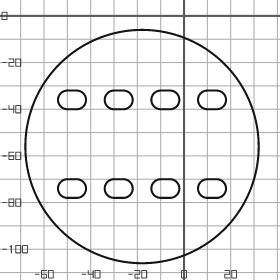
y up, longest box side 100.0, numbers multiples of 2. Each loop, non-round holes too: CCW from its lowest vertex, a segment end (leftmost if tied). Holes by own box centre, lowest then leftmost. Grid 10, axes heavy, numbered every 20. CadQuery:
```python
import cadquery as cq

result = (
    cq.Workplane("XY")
    .moveTo(-18.0, -56.0)
    .circle(50.0)
    .moveTo(-50.0, -78.0)
    .lineTo(-46.0, -78.0)
    .threePointArc((-42.0, -74.0), (-46.0, -70.0))
    .lineTo(-50.0, -70.0)
    .threePointArc((-54.0, -74.0), (-50.0, -78.0))
    .close()
    .moveTo(-30.0, -78.0)
    .lineTo(-26.0, -78.0)
    .threePointArc((-22.0, -74.0), (-26.0, -70.0))
    .lineTo(-30.0, -70.0)
    .threePointArc((-34.0, -74.0), (-30.0, -78.0))
    .close()
    .moveTo(-10.0, -78.0)
    .lineTo(-6.0, -78.0)
    .threePointArc((-2.0, -74.0), (-6.0, -70.0))
    .lineTo(-10.0, -70.0)
    .threePointArc((-14.0, -74.0), (-10.0, -78.0))
    .close()
    .moveTo(10.0, -78.0)
    .lineTo(14.0, -78.0)
    .threePointArc((18.0, -74.0), (14.0, -70.0))
    .lineTo(10.0, -70.0)
    .threePointArc((6.0, -74.0), (10.0, -78.0))
    .close()
    .moveTo(-50.0, -40.0)
    .lineTo(-46.0, -40.0)
    .threePointArc((-42.0, -36.0), (-46.0, -32.0))
    .lineTo(-50.0, -32.0)
    .threePointArc((-54.0, -36.0), (-50.0, -40.0))
    .close()
    .moveTo(-30.0, -40.0)
    .lineTo(-26.0, -40.0)
    .threePointArc((-22.0, -36.0), (-26.0, -32.0))
    .lineTo(-30.0, -32.0)
    .threePointArc((-34.0, -36.0), (-30.0, -40.0))
    .close()
    .moveTo(-10.0, -40.0)
    .lineTo(-6.0, -40.0)
    .threePointArc((-2.0, -36.0), (-6.0, -32.0))
    .lineTo(-10.0, -32.0)
    .threePointArc((-14.0, -36.0), (-10.0, -40.0))
    .close()
    .moveTo(10.0, -40.0)
    .lineTo(14.0, -40.0)
    .threePointArc((18.0, -36.0), (14.0, -32.0))
    .lineTo(10.0, -32.0)
    .threePointArc((6.0, -36.0), (10.0, -40.0))
    .close()
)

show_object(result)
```